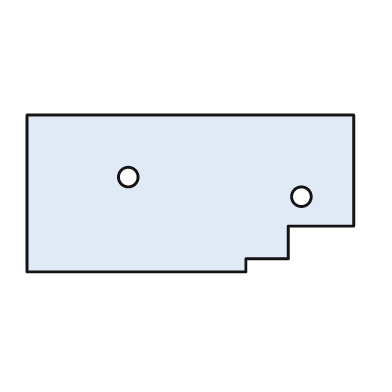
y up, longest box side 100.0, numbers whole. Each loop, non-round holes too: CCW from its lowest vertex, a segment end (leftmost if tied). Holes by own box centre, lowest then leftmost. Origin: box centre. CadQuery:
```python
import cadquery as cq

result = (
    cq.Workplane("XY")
    .moveTo(-50.0, -24.0)
    .lineTo(17.0, -24.0)
    .lineTo(17.0, -20.0)
    .lineTo(30.0, -20.0)
    .lineTo(30.0, -10.0)
    .lineTo(50.0, -10.0)
    .lineTo(50.0, 24.0)
    .lineTo(-50.0, 24.0)
    .close()
    .moveTo(34.0, -1.0)
    .circle(3.0)
    .moveTo(-19.0, 5.0)
    .circle(3.0)
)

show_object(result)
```